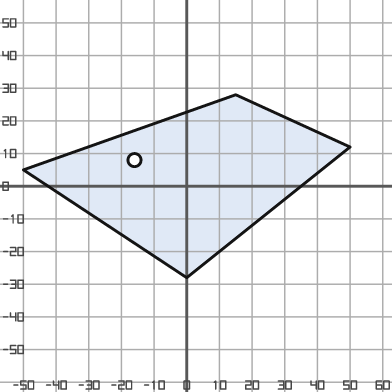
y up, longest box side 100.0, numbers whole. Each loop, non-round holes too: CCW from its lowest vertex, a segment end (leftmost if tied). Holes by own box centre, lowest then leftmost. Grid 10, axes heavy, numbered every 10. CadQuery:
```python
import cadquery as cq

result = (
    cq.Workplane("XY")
    .moveTo(0.0, -28.0)
    .lineTo(50.0, 12.0)
    .lineTo(15.0, 28.0)
    .lineTo(-50.0, 5.0)
    .close()
    .moveTo(-16.0, 8.0)
    .circle(2.0)
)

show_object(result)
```